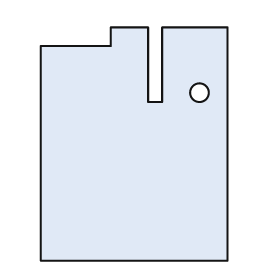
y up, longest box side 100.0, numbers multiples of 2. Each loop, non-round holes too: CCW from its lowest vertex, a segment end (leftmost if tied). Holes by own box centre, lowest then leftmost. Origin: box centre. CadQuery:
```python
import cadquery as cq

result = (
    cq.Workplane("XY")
    .moveTo(-40.0, -50.0)
    .lineTo(40.0, -50.0)
    .lineTo(40.0, 50.0)
    .lineTo(12.0, 50.0)
    .lineTo(12.0, 18.0)
    .lineTo(6.0, 18.0)
    .lineTo(6.0, 50.0)
    .lineTo(-10.0, 50.0)
    .lineTo(-10.0, 42.0)
    .lineTo(-40.0, 42.0)
    .close()
    .moveTo(28.0, 22.0)
    .circle(4.0)
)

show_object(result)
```